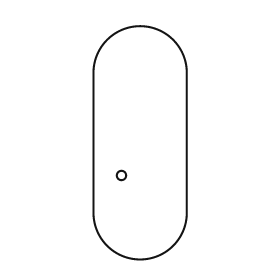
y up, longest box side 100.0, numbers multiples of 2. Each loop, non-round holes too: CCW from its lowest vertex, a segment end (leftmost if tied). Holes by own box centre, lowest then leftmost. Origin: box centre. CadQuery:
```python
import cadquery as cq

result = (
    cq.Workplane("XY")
    .moveTo(-20.0, -30.0)
    .threePointArc((0.0, -50.0), (20.0, -30.0))
    .lineTo(20.0, 30.0)
    .threePointArc((0.0, 50.0), (-20.0, 30.0))
    .close()
    .moveTo(-8.0, -14.0)
    .circle(2.0)
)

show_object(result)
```